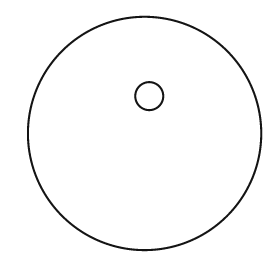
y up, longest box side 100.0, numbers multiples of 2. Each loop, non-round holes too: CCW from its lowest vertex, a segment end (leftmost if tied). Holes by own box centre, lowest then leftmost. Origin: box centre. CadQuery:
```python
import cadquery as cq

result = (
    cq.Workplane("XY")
    .moveTo(0.0, 0.0)
    .circle(50.0)
    .moveTo(2.0, 16.0)
    .circle(6.0)
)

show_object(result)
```